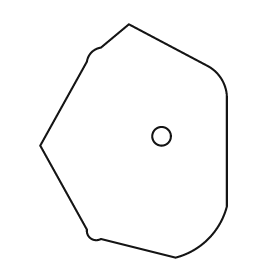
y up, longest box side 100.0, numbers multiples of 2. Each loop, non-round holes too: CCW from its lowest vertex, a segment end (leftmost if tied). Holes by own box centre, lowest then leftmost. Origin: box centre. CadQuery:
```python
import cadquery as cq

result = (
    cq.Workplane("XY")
    .moveTo(18.0, -50.0)
    .threePointArc((32.0, -42.0), (40.0, -28.0))
    .lineTo(40.0, 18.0)
    .threePointArc((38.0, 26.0), (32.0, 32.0))
    .lineTo(-2.0, 50.0)
    .lineTo(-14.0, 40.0)
    .threePointArc((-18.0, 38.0), (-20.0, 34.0))
    .lineTo(-40.0, -2.0)
    .lineTo(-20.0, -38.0)
    .threePointArc((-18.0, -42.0), (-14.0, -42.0))
    .close()
    .moveTo(12.0, 2.0)
    .circle(4.0)
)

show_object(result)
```